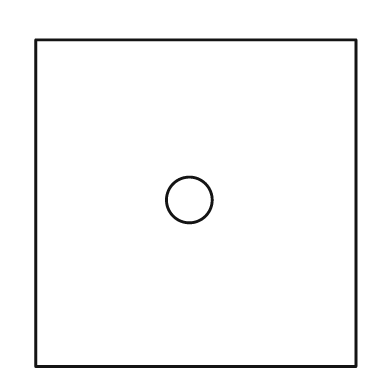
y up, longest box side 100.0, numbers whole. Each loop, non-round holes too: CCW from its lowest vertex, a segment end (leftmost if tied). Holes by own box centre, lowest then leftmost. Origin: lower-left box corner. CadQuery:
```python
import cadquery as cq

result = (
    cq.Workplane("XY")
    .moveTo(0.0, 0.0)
    .lineTo(98.0, 0.0)
    .lineTo(98.0, 100.0)
    .lineTo(0.0, 100.0)
    .close()
    .moveTo(47.0, 51.0)
    .circle(7.0)
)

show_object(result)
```